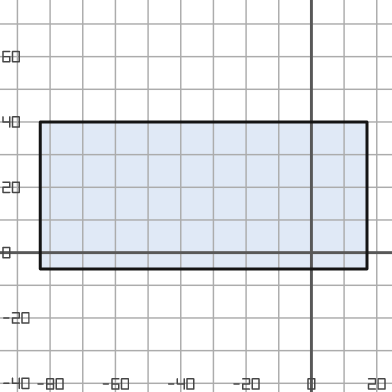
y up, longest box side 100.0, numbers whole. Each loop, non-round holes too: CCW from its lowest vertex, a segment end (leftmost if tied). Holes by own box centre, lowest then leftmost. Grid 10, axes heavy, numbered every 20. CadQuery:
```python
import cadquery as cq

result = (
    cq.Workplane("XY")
    .moveTo(-83.0, -5.0)
    .lineTo(17.0, -5.0)
    .lineTo(17.0, 40.0)
    .lineTo(-83.0, 40.0)
    .close()
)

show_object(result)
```